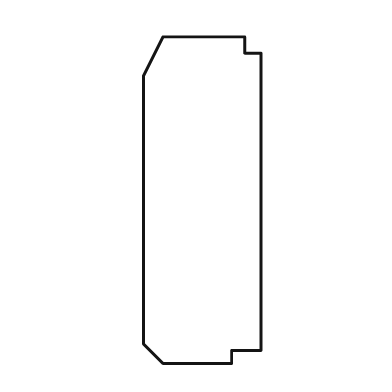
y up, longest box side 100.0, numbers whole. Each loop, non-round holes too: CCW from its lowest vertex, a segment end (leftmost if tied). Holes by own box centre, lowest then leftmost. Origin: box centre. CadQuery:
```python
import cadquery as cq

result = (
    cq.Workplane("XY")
    .moveTo(-12.0, -50.0)
    .lineTo(9.0, -50.0)
    .lineTo(9.0, -46.0)
    .lineTo(18.0, -46.0)
    .lineTo(18.0, 45.0)
    .lineTo(13.0, 45.0)
    .lineTo(13.0, 50.0)
    .lineTo(-12.0, 50.0)
    .lineTo(-18.0, 38.0)
    .lineTo(-18.0, -44.0)
    .close()
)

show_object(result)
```